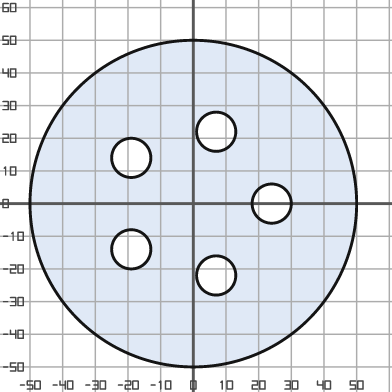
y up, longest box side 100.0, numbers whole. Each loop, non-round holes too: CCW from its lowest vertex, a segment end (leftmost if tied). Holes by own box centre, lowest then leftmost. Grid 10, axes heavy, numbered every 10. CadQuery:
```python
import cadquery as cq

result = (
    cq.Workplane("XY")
    .moveTo(0.0, 0.0)
    .circle(50.0)
    .moveTo(7.0, -22.0)
    .circle(6.0)
    .moveTo(-19.0, -14.0)
    .circle(6.0)
    .moveTo(24.0, 0.0)
    .circle(6.0)
    .moveTo(-19.0, 14.0)
    .circle(6.0)
    .moveTo(7.0, 22.0)
    .circle(6.0)
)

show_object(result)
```